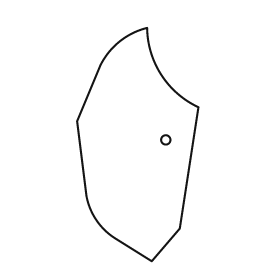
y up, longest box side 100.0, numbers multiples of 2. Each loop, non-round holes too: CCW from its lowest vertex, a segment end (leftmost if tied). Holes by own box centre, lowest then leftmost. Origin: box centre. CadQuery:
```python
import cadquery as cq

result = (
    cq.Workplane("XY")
    .moveTo(6.0, -50.0)
    .lineTo(18.0, -36.0)
    .lineTo(26.0, 16.0)
    .threePointArc((10.0, 30.0), (4.0, 50.0))
    .threePointArc((-8.0, 44.0), (-16.0, 34.0))
    .lineTo(-26.0, 10.0)
    .lineTo(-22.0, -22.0)
    .threePointArc((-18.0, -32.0), (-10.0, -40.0))
    .close()
    .moveTo(12.0, 2.0)
    .circle(2.0)
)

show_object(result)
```